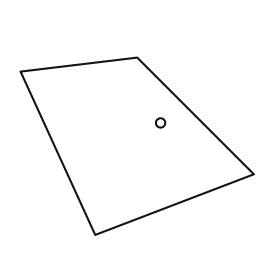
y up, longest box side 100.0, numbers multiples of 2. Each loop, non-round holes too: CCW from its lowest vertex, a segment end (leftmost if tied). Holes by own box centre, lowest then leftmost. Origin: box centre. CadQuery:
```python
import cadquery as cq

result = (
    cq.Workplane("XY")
    .moveTo(-18.0, -38.0)
    .lineTo(50.0, -12.0)
    .lineTo(0.0, 38.0)
    .lineTo(-50.0, 32.0)
    .close()
    .moveTo(10.0, 10.0)
    .circle(2.0)
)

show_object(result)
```